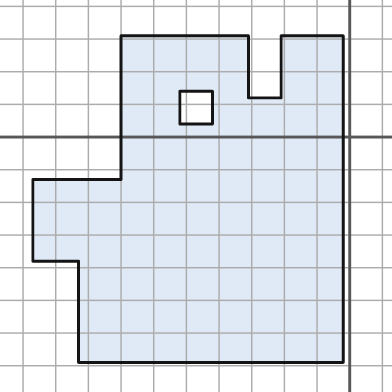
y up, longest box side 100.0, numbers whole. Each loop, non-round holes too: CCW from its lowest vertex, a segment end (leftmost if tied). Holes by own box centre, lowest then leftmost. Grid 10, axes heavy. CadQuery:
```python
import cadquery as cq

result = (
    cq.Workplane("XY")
    .moveTo(-83.0, -69.0)
    .lineTo(-2.0, -69.0)
    .lineTo(-2.0, 31.0)
    .lineTo(-21.0, 31.0)
    .lineTo(-21.0, 12.0)
    .lineTo(-31.0, 12.0)
    .lineTo(-31.0, 31.0)
    .lineTo(-70.0, 31.0)
    .lineTo(-70.0, -13.0)
    .lineTo(-97.0, -13.0)
    .lineTo(-97.0, -38.0)
    .lineTo(-83.0, -38.0)
    .close()
    .moveTo(-52.0, 4.0)
    .lineTo(-42.0, 4.0)
    .lineTo(-42.0, 14.0)
    .lineTo(-52.0, 14.0)
    .close()
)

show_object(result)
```